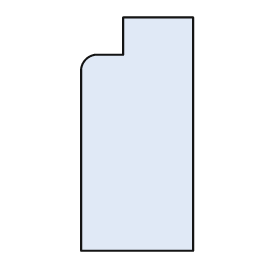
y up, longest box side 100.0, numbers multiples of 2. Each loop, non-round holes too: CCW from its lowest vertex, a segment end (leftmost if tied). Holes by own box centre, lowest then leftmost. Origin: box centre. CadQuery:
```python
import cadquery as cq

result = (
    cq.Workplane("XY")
    .moveTo(-24.0, -50.0)
    .lineTo(24.0, -50.0)
    .lineTo(24.0, 50.0)
    .lineTo(-6.0, 50.0)
    .lineTo(-6.0, 34.0)
    .lineTo(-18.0, 34.0)
    .threePointArc((-22.0, 32.0), (-24.0, 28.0))
    .close()
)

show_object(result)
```